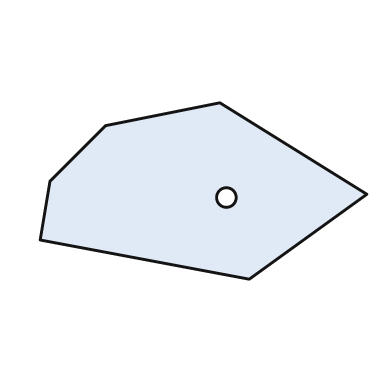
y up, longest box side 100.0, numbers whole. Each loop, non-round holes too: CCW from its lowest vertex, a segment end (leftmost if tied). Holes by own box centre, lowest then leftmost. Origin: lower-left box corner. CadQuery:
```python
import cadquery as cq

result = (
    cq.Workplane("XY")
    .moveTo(64.0, 0.0)
    .lineTo(100.0, 26.0)
    .lineTo(55.0, 54.0)
    .lineTo(20.0, 47.0)
    .lineTo(3.0, 30.0)
    .lineTo(0.0, 12.0)
    .close()
    .moveTo(57.0, 25.0)
    .circle(3.0)
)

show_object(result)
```